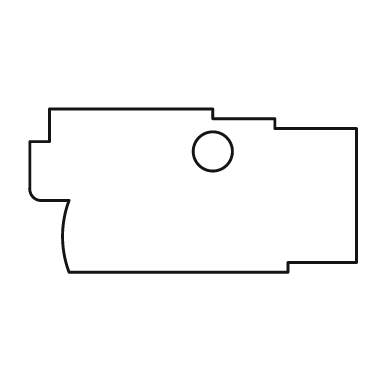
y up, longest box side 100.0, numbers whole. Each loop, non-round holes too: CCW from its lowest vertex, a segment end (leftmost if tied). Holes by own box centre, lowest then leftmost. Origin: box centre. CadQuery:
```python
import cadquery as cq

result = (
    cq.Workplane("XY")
    .moveTo(-38.0, -25.0)
    .lineTo(29.0, -25.0)
    .lineTo(29.0, -22.0)
    .lineTo(50.0, -22.0)
    .lineTo(50.0, 19.0)
    .lineTo(25.0, 19.0)
    .lineTo(25.0, 22.0)
    .lineTo(6.0, 22.0)
    .lineTo(6.0, 25.0)
    .lineTo(-44.0, 25.0)
    .lineTo(-44.0, 15.0)
    .lineTo(-50.0, 15.0)
    .lineTo(-50.0, 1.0)
    .threePointArc((-49.0, -2.0), (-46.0, -3.0))
    .lineTo(-38.0, -3.0)
    .threePointArc((-40.0, -14.0), (-38.0, -25.0))
    .close()
    .moveTo(6.0, 12.0)
    .circle(6.0)
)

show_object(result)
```